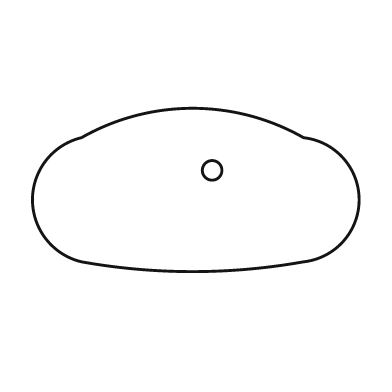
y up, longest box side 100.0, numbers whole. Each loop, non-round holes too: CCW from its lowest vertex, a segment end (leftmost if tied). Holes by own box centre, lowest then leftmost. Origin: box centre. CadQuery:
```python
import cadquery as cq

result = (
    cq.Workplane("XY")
    .moveTo(-35.0, -22.0)
    .threePointArc((-1.0, -25.0), (33.0, -22.0))
    .threePointArc((50.0, -3.0), (33.0, 16.0))
    .threePointArc((-1.0, 25.0), (-35.0, 16.0))
    .threePointArc((-50.0, -3.0), (-35.0, -22.0))
    .close()
    .moveTo(5.0, 6.0)
    .circle(3.0)
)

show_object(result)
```